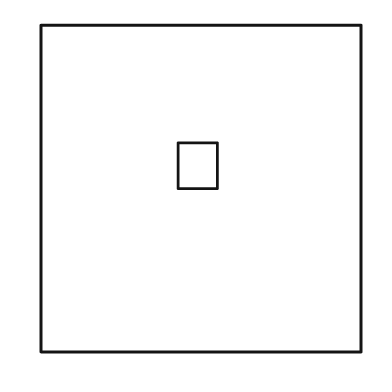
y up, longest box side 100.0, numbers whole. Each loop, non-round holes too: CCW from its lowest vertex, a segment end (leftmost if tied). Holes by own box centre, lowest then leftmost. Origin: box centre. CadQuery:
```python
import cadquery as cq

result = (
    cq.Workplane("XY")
    .moveTo(-49.0, -50.0)
    .lineTo(49.0, -50.0)
    .lineTo(49.0, 50.0)
    .lineTo(-49.0, 50.0)
    .close()
    .moveTo(-7.0, 0.0)
    .lineTo(5.0, 0.0)
    .lineTo(5.0, 14.0)
    .lineTo(-7.0, 14.0)
    .close()
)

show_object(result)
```